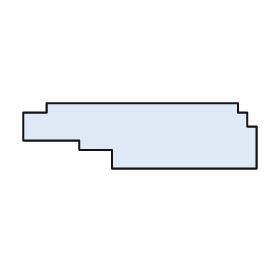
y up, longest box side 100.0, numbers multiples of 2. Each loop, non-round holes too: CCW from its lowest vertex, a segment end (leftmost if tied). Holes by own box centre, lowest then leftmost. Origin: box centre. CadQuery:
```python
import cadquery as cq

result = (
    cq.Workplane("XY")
    .moveTo(-12.0, -14.0)
    .lineTo(50.0, -14.0)
    .lineTo(50.0, 4.0)
    .lineTo(46.0, 4.0)
    .lineTo(46.0, 10.0)
    .lineTo(42.0, 10.0)
    .lineTo(42.0, 14.0)
    .lineTo(-40.0, 14.0)
    .lineTo(-40.0, 10.0)
    .lineTo(-50.0, 10.0)
    .lineTo(-50.0, -2.0)
    .lineTo(-26.0, -2.0)
    .lineTo(-26.0, -6.0)
    .lineTo(-12.0, -6.0)
    .close()
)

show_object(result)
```